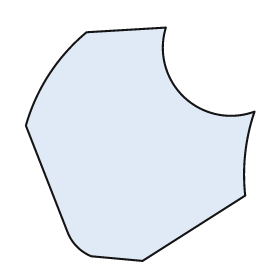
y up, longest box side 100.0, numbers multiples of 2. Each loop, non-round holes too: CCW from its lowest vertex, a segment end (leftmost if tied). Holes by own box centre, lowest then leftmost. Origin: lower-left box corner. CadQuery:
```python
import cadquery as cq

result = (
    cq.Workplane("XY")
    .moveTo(50.0, 0.0)
    .lineTo(94.0, 28.0)
    .threePointArc((94.0, 46.0), (98.0, 64.0))
    .threePointArc((68.0, 70.0), (60.0, 100.0))
    .lineTo(26.0, 98.0)
    .threePointArc((10.0, 80.0), (0.0, 58.0))
    .lineTo(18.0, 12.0)
    .threePointArc((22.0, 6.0), (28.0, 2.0))
    .close()
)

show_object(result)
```